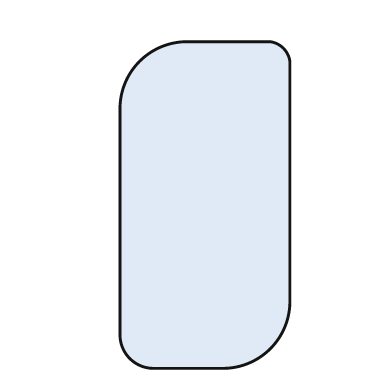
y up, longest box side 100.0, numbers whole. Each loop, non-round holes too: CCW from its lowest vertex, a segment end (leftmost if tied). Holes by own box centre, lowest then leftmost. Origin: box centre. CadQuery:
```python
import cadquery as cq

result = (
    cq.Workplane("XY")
    .moveTo(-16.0, -50.0)
    .lineTo(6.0, -50.0)
    .threePointArc((20.0, -44.0), (26.0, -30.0))
    .lineTo(26.0, 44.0)
    .threePointArc((24.0, 48.0), (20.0, 50.0))
    .lineTo(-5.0, 50.0)
    .threePointArc((-20.0, 44.0), (-26.0, 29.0))
    .lineTo(-26.0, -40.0)
    .threePointArc((-23.0, -47.0), (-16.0, -50.0))
    .close()
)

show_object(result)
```